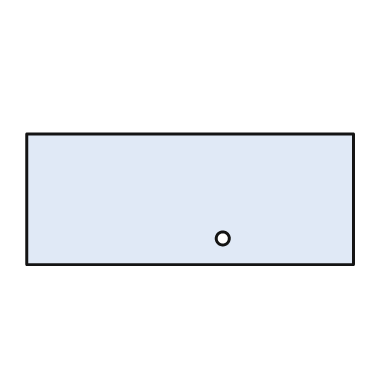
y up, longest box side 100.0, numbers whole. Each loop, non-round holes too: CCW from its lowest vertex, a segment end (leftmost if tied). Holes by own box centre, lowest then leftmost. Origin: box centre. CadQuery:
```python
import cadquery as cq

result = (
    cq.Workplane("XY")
    .moveTo(-50.0, -20.0)
    .lineTo(50.0, -20.0)
    .lineTo(50.0, 20.0)
    .lineTo(-50.0, 20.0)
    .close()
    .moveTo(10.0, -12.0)
    .circle(2.0)
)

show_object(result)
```